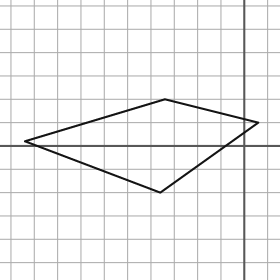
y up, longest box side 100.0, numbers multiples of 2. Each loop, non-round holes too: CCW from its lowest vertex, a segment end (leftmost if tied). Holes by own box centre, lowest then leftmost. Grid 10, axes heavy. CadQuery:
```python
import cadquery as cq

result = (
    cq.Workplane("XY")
    .moveTo(-36.0, -20.0)
    .lineTo(6.0, 10.0)
    .lineTo(-34.0, 20.0)
    .lineTo(-94.0, 2.0)
    .close()
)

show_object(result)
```